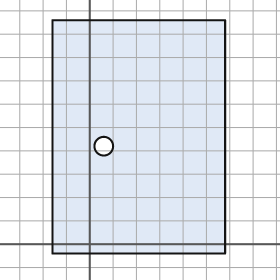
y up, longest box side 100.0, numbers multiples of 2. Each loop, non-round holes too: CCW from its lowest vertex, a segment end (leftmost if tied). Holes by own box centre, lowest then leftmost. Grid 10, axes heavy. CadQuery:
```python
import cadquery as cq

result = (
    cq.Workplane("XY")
    .moveTo(-16.0, -4.0)
    .lineTo(58.0, -4.0)
    .lineTo(58.0, 96.0)
    .lineTo(-16.0, 96.0)
    .close()
    .moveTo(6.0, 42.0)
    .circle(4.0)
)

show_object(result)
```